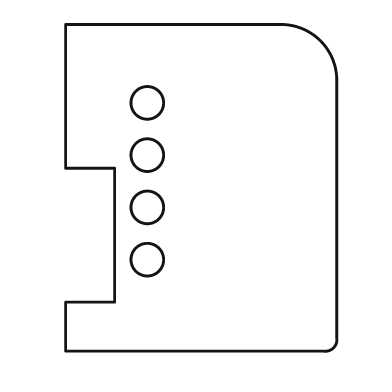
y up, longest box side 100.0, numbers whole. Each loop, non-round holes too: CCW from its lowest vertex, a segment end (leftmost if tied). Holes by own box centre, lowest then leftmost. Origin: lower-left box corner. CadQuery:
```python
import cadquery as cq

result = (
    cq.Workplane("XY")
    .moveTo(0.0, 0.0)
    .lineTo(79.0, 0.0)
    .threePointArc((82.0, 1.0), (83.0, 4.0))
    .lineTo(83.0, 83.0)
    .threePointArc((78.0, 95.0), (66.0, 100.0))
    .lineTo(0.0, 100.0)
    .lineTo(0.0, 56.0)
    .lineTo(15.0, 56.0)
    .lineTo(15.0, 15.0)
    .lineTo(0.0, 15.0)
    .close()
    .moveTo(25.0, 28.0)
    .circle(5.0)
    .moveTo(25.0, 44.0)
    .circle(5.0)
    .moveTo(25.0, 60.0)
    .circle(5.0)
    .moveTo(25.0, 76.0)
    .circle(5.0)
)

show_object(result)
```